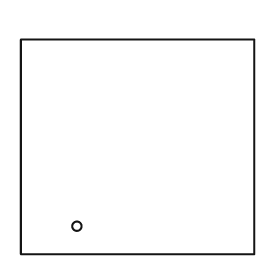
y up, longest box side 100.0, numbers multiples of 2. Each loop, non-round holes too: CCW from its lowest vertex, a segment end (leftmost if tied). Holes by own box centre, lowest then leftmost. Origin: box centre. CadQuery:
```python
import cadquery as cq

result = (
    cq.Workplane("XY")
    .moveTo(-50.0, -46.0)
    .lineTo(50.0, -46.0)
    .lineTo(50.0, 46.0)
    .lineTo(-50.0, 46.0)
    .close()
    .moveTo(-26.0, -34.0)
    .circle(2.0)
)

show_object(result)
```